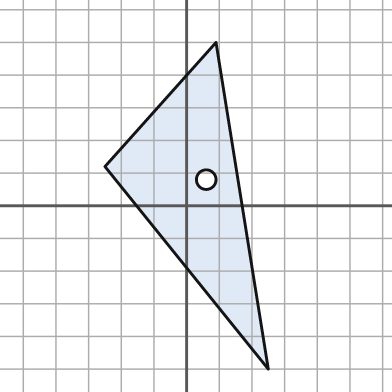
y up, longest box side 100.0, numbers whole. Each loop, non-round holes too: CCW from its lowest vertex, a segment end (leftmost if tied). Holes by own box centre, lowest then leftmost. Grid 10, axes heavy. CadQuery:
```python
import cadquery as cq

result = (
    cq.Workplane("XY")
    .moveTo(25.0, -50.0)
    .lineTo(9.0, 50.0)
    .lineTo(-25.0, 12.0)
    .close()
    .moveTo(6.0, 8.0)
    .circle(3.0)
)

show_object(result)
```